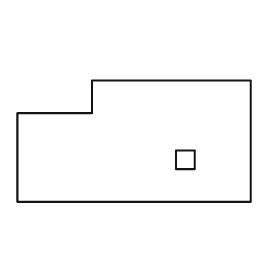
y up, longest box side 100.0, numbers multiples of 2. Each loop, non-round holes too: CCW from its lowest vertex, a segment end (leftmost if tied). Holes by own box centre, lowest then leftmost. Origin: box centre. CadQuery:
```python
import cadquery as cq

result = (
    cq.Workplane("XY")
    .moveTo(-50.0, -26.0)
    .lineTo(50.0, -26.0)
    .lineTo(50.0, 26.0)
    .lineTo(-18.0, 26.0)
    .lineTo(-18.0, 12.0)
    .lineTo(-50.0, 12.0)
    .close()
    .moveTo(18.0, -12.0)
    .lineTo(26.0, -12.0)
    .lineTo(26.0, -4.0)
    .lineTo(18.0, -4.0)
    .close()
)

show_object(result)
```